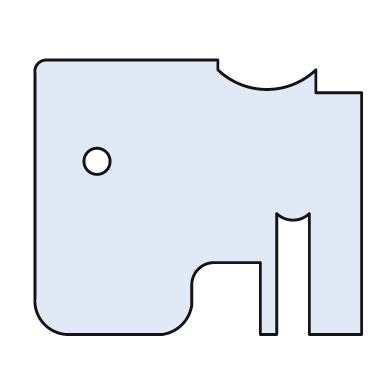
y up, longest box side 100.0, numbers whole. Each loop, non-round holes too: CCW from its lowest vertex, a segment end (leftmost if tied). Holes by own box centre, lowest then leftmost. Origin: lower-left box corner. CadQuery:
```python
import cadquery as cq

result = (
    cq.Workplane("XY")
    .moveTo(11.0, 0.0)
    .lineTo(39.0, 0.0)
    .threePointArc((45.0, 3.0), (48.0, 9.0))
    .lineTo(48.0, 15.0)
    .threePointArc((50.0, 20.0), (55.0, 22.0))
    .lineTo(69.0, 22.0)
    .lineTo(69.0, 0.0)
    .lineTo(74.0, 0.0)
    .lineTo(74.0, 37.0)
    .threePointArc((79.0, 35.0), (84.0, 37.0))
    .lineTo(84.0, 0.0)
    .lineTo(100.0, 0.0)
    .lineTo(100.0, 74.0)
    .lineTo(86.0, 74.0)
    .lineTo(86.0, 81.0)
    .threePointArc((71.0, 75.0), (56.0, 81.0))
    .lineTo(56.0, 84.0)
    .lineTo(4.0, 84.0)
    .threePointArc((1.0, 83.0), (0.0, 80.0))
    .lineTo(0.0, 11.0)
    .threePointArc((3.0, 3.0), (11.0, 0.0))
    .close()
    .moveTo(19.0, 53.0)
    .circle(4.0)
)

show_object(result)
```